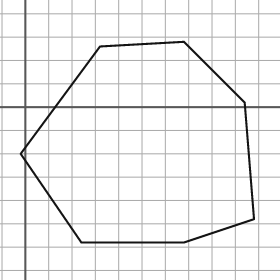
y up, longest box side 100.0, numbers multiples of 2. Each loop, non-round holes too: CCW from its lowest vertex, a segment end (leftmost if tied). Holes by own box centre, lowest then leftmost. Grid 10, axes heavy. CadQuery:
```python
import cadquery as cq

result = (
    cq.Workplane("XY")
    .moveTo(24.0, -58.0)
    .lineTo(68.0, -58.0)
    .lineTo(98.0, -48.0)
    .lineTo(94.0, 2.0)
    .lineTo(68.0, 28.0)
    .lineTo(32.0, 26.0)
    .lineTo(-2.0, -20.0)
    .close()
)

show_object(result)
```